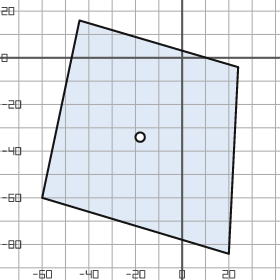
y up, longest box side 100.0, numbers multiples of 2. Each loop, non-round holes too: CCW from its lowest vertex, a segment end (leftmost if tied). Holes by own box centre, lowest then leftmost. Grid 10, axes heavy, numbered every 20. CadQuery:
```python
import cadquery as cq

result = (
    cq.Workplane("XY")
    .moveTo(20.0, -84.0)
    .lineTo(24.0, -4.0)
    .lineTo(-44.0, 16.0)
    .lineTo(-60.0, -60.0)
    .close()
    .moveTo(-18.0, -34.0)
    .circle(2.0)
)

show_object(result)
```